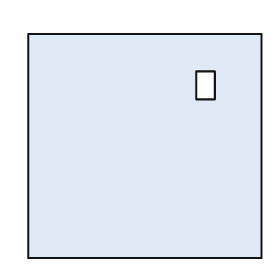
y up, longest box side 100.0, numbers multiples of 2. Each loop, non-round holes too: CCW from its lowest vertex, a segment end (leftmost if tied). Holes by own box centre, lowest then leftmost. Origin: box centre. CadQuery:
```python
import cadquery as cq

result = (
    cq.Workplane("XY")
    .moveTo(-50.0, -48.0)
    .lineTo(50.0, -48.0)
    .lineTo(50.0, 48.0)
    .lineTo(-50.0, 48.0)
    .close()
    .moveTo(22.0, 20.0)
    .lineTo(30.0, 20.0)
    .lineTo(30.0, 32.0)
    .lineTo(22.0, 32.0)
    .close()
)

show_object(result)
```